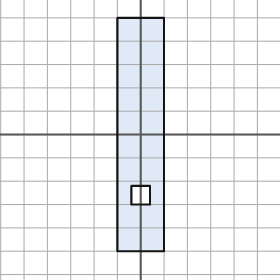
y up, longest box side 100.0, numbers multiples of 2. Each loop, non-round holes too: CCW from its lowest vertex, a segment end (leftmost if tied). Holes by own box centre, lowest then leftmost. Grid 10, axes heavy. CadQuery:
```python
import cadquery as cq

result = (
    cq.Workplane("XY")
    .moveTo(-10.0, -50.0)
    .lineTo(10.0, -50.0)
    .lineTo(10.0, 50.0)
    .lineTo(-10.0, 50.0)
    .close()
    .moveTo(-4.0, -30.0)
    .lineTo(4.0, -30.0)
    .lineTo(4.0, -22.0)
    .lineTo(-4.0, -22.0)
    .close()
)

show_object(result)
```